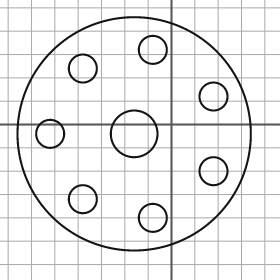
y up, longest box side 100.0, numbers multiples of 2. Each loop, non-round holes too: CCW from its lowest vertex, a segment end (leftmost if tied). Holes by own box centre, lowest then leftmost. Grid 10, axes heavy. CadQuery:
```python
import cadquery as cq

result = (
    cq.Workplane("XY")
    .moveTo(-16.0, -4.0)
    .circle(50.0)
    .moveTo(-8.0, -40.0)
    .circle(6.0)
    .moveTo(-38.0, -32.0)
    .circle(6.0)
    .moveTo(18.0, -20.0)
    .circle(6.0)
    .moveTo(-52.0, -4.0)
    .circle(6.0)
    .moveTo(-16.0, -4.0)
    .circle(10.0)
    .moveTo(18.0, 12.0)
    .circle(6.0)
    .moveTo(-38.0, 24.0)
    .circle(6.0)
    .moveTo(-8.0, 32.0)
    .circle(6.0)
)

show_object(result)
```